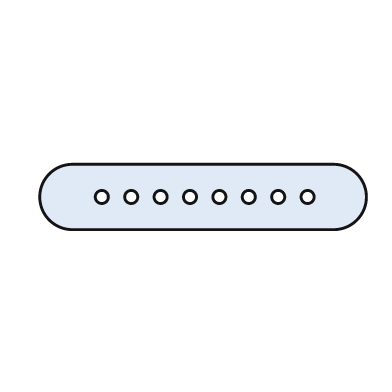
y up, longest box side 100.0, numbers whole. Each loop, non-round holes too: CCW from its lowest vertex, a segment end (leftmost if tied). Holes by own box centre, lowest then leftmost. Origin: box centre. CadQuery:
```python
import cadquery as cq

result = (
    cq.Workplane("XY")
    .moveTo(-40.0, -10.0)
    .lineTo(40.0, -10.0)
    .threePointArc((50.0, 0.0), (40.0, 10.0))
    .lineTo(-40.0, 10.0)
    .threePointArc((-50.0, 0.0), (-40.0, -10.0))
    .close()
    .moveTo(-31.0, 0.0)
    .circle(2.0)
    .moveTo(-22.0, 0.0)
    .circle(2.0)
    .moveTo(-13.0, 0.0)
    .circle(2.0)
    .moveTo(-4.0, 0.0)
    .circle(2.0)
    .moveTo(5.0, 0.0)
    .circle(2.0)
    .moveTo(14.0, 0.0)
    .circle(2.0)
    .moveTo(23.0, 0.0)
    .circle(2.0)
    .moveTo(32.0, 0.0)
    .circle(2.0)
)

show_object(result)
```